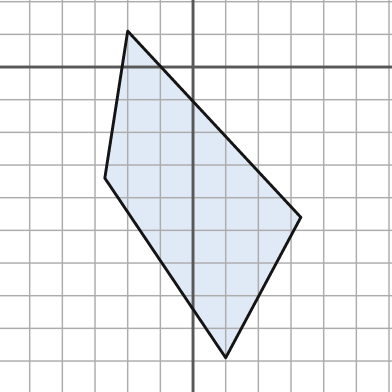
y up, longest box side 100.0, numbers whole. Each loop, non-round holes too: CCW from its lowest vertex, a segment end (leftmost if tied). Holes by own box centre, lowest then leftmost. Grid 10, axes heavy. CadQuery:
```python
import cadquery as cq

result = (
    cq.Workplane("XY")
    .moveTo(10.0, -89.0)
    .lineTo(33.0, -46.0)
    .lineTo(-20.0, 11.0)
    .lineTo(-27.0, -34.0)
    .close()
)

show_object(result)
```